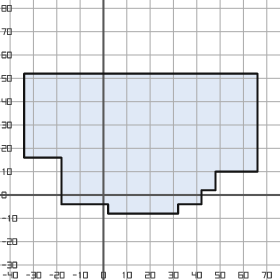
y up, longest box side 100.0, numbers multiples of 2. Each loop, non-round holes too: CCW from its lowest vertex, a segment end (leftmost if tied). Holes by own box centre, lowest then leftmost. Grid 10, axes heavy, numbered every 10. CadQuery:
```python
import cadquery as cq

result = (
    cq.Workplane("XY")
    .moveTo(2.0, -8.0)
    .lineTo(32.0, -8.0)
    .lineTo(32.0, -4.0)
    .lineTo(42.0, -4.0)
    .lineTo(42.0, 2.0)
    .lineTo(48.0, 2.0)
    .lineTo(48.0, 10.0)
    .lineTo(66.0, 10.0)
    .lineTo(66.0, 52.0)
    .lineTo(-34.0, 52.0)
    .lineTo(-34.0, 16.0)
    .lineTo(-18.0, 16.0)
    .lineTo(-18.0, -4.0)
    .lineTo(2.0, -4.0)
    .close()
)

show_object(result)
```